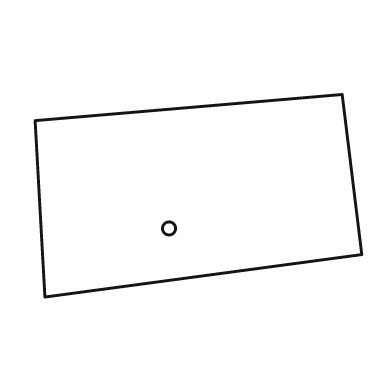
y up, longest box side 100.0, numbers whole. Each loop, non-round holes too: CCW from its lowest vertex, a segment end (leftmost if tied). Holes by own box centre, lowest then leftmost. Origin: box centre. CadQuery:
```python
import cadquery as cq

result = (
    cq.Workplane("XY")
    .moveTo(-47.0, -31.0)
    .lineTo(50.0, -18.0)
    .lineTo(44.0, 31.0)
    .lineTo(-50.0, 23.0)
    .close()
    .moveTo(-9.0, -10.0)
    .circle(2.0)
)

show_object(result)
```